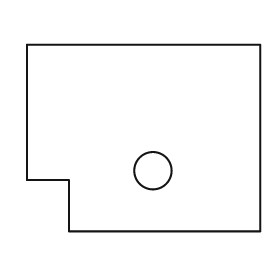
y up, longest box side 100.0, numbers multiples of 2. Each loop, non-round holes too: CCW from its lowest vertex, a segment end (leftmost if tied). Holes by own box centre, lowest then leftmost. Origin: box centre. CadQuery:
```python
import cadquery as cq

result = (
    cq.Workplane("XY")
    .moveTo(-32.0, -40.0)
    .lineTo(50.0, -40.0)
    .lineTo(50.0, 40.0)
    .lineTo(-50.0, 40.0)
    .lineTo(-50.0, -18.0)
    .lineTo(-32.0, -18.0)
    .close()
    .moveTo(4.0, -14.0)
    .circle(8.0)
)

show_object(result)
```